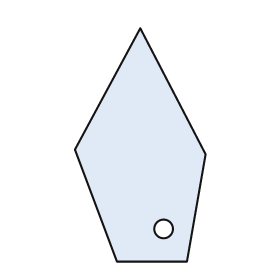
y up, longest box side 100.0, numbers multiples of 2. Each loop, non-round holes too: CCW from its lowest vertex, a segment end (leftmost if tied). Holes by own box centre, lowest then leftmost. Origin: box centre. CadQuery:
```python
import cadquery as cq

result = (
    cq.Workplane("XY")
    .moveTo(-10.0, -50.0)
    .lineTo(20.0, -50.0)
    .lineTo(28.0, -4.0)
    .lineTo(0.0, 50.0)
    .lineTo(-28.0, -2.0)
    .close()
    .moveTo(10.0, -36.0)
    .circle(4.0)
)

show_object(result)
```